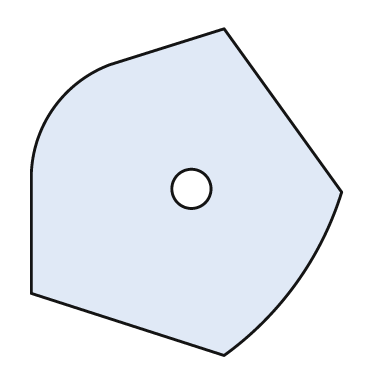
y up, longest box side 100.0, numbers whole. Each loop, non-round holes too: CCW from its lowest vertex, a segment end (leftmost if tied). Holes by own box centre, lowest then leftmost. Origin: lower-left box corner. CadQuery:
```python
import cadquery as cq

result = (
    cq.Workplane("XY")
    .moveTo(59.0, 0.0)
    .threePointArc((81.0, 22.0), (95.0, 50.0))
    .lineTo(59.0, 100.0)
    .lineTo(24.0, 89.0)
    .threePointArc((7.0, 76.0), (0.0, 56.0))
    .lineTo(0.0, 19.0)
    .close()
    .moveTo(49.0, 51.0)
    .circle(6.0)
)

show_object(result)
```